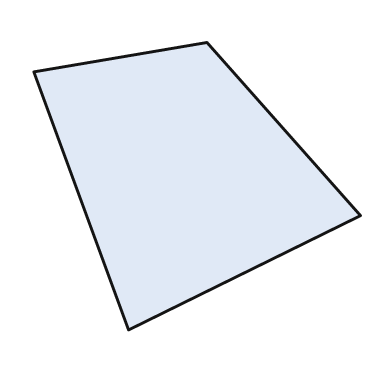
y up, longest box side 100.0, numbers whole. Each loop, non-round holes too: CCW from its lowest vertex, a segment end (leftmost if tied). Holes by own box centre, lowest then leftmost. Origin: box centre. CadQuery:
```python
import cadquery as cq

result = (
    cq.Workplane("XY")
    .moveTo(-21.0, -44.0)
    .lineTo(50.0, -9.0)
    .lineTo(3.0, 44.0)
    .lineTo(-50.0, 35.0)
    .close()
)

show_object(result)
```